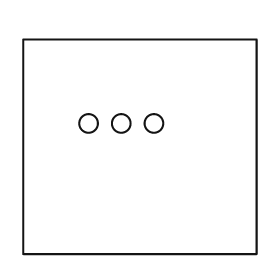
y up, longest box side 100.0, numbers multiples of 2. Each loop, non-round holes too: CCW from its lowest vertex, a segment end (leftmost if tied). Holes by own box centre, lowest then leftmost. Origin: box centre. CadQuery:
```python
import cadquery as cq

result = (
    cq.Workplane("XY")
    .moveTo(-50.0, -46.0)
    .lineTo(50.0, -46.0)
    .lineTo(50.0, 46.0)
    .lineTo(-50.0, 46.0)
    .close()
    .moveTo(-22.0, 10.0)
    .circle(4.0)
    .moveTo(-8.0, 10.0)
    .circle(4.0)
    .moveTo(6.0, 10.0)
    .circle(4.0)
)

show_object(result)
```